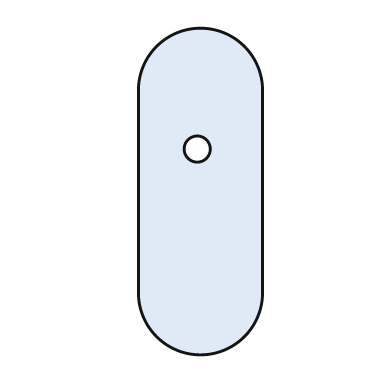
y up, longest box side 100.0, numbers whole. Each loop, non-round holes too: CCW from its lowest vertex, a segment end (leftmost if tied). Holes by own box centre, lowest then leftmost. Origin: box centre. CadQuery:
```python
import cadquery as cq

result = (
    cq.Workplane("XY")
    .moveTo(-19.0, -31.0)
    .threePointArc((0.0, -50.0), (19.0, -31.0))
    .lineTo(19.0, 31.0)
    .threePointArc((0.0, 50.0), (-19.0, 31.0))
    .close()
    .moveTo(-1.0, 13.0)
    .circle(4.0)
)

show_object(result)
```